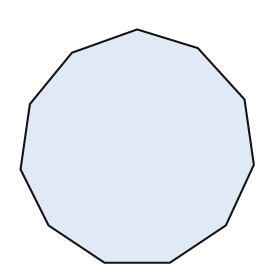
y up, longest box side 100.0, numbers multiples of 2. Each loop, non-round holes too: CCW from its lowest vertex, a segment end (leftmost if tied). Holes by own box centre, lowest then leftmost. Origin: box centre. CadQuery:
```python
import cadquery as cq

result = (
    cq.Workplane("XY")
    .moveTo(-14.0, -50.0)
    .lineTo(14.0, -50.0)
    .lineTo(38.0, -34.0)
    .lineTo(50.0, -8.0)
    .lineTo(46.0, 20.0)
    .lineTo(26.0, 42.0)
    .lineTo(0.0, 50.0)
    .lineTo(-28.0, 40.0)
    .lineTo(-46.0, 18.0)
    .lineTo(-50.0, -10.0)
    .lineTo(-38.0, -34.0)
    .close()
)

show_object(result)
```